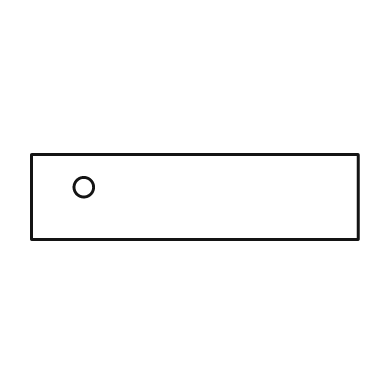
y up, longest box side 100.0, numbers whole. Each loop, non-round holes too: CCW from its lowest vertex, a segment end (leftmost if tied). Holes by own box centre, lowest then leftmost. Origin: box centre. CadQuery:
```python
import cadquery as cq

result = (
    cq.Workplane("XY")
    .moveTo(-50.0, -13.0)
    .lineTo(50.0, -13.0)
    .lineTo(50.0, 13.0)
    .lineTo(-50.0, 13.0)
    .close()
    .moveTo(-34.0, 3.0)
    .circle(3.0)
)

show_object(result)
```